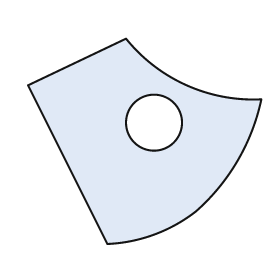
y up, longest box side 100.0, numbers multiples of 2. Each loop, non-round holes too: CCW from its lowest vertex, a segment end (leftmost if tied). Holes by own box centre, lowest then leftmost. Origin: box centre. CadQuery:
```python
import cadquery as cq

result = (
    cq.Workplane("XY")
    .moveTo(-16.0, -44.0)
    .threePointArc((4.0, -40.0), (22.0, -30.0))
    .threePointArc((40.0, -8.0), (50.0, 18.0))
    .threePointArc((18.0, 24.0), (-8.0, 44.0))
    .lineTo(-50.0, 24.0)
    .close()
    .moveTo(4.0, 8.0)
    .circle(12.0)
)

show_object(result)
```